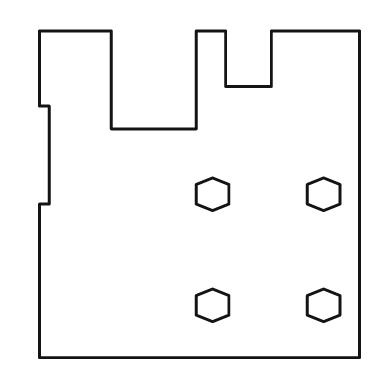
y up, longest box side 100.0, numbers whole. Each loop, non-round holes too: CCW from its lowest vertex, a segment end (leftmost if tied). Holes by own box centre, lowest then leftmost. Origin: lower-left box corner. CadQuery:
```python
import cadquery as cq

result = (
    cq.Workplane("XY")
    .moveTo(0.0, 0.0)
    .lineTo(98.0, 0.0)
    .lineTo(98.0, 100.0)
    .lineTo(71.0, 100.0)
    .lineTo(71.0, 83.0)
    .lineTo(57.0, 83.0)
    .lineTo(57.0, 100.0)
    .lineTo(48.0, 100.0)
    .lineTo(48.0, 70.0)
    .lineTo(22.0, 70.0)
    .lineTo(22.0, 100.0)
    .lineTo(0.0, 100.0)
    .lineTo(0.0, 77.0)
    .lineTo(3.0, 77.0)
    .lineTo(3.0, 47.0)
    .lineTo(0.0, 47.0)
    .close()
    .moveTo(53.0, 11.0)
    .lineTo(58.0, 13.0)
    .lineTo(58.0, 19.0)
    .lineTo(53.0, 21.0)
    .lineTo(48.0, 19.0)
    .lineTo(48.0, 13.0)
    .close()
    .moveTo(87.0, 11.0)
    .lineTo(92.0, 13.0)
    .lineTo(92.0, 19.0)
    .lineTo(87.0, 21.0)
    .lineTo(82.0, 19.0)
    .lineTo(82.0, 13.0)
    .close()
    .moveTo(53.0, 45.0)
    .lineTo(58.0, 47.0)
    .lineTo(58.0, 53.0)
    .lineTo(53.0, 55.0)
    .lineTo(48.0, 53.0)
    .lineTo(48.0, 47.0)
    .close()
    .moveTo(87.0, 45.0)
    .lineTo(92.0, 47.0)
    .lineTo(92.0, 53.0)
    .lineTo(87.0, 55.0)
    .lineTo(82.0, 53.0)
    .lineTo(82.0, 47.0)
    .close()
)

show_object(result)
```